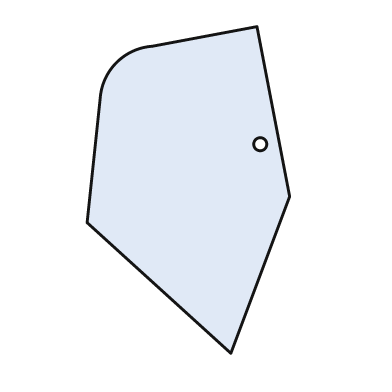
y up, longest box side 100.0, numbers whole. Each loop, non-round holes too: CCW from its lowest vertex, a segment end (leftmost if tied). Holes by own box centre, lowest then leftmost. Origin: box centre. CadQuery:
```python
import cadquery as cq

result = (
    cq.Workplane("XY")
    .moveTo(13.0, -50.0)
    .lineTo(31.0, -2.0)
    .lineTo(21.0, 50.0)
    .lineTo(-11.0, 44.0)
    .threePointArc((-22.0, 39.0), (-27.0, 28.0))
    .lineTo(-31.0, -10.0)
    .close()
    .moveTo(22.0, 14.0)
    .circle(2.0)
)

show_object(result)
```